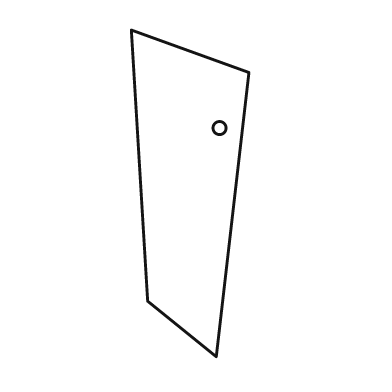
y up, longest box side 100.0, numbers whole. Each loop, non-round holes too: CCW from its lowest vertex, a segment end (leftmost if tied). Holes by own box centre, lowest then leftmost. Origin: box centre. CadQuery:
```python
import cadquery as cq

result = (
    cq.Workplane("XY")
    .moveTo(8.0, -50.0)
    .lineTo(18.0, 37.0)
    .lineTo(-18.0, 50.0)
    .lineTo(-13.0, -33.0)
    .close()
    .moveTo(9.0, 20.0)
    .circle(2.0)
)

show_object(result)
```